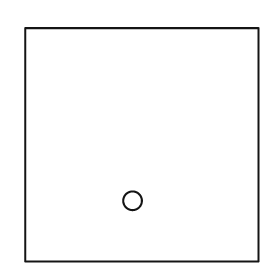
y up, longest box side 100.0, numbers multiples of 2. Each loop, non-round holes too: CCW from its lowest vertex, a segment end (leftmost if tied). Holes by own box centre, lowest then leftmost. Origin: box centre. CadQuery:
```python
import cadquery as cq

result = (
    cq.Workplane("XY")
    .moveTo(-50.0, -50.0)
    .lineTo(50.0, -50.0)
    .lineTo(50.0, 50.0)
    .lineTo(-50.0, 50.0)
    .close()
    .moveTo(-4.0, -24.0)
    .circle(4.0)
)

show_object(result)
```